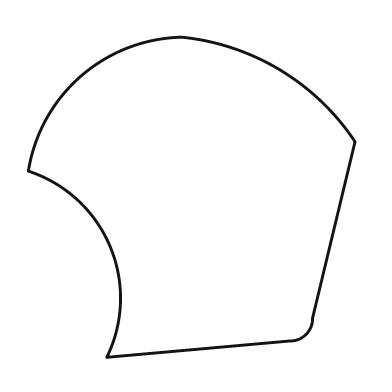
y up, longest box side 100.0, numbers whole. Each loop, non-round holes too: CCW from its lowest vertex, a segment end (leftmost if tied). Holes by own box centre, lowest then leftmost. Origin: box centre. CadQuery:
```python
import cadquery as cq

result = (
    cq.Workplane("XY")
    .moveTo(-26.0, -49.0)
    .lineTo(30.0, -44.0)
    .threePointArc((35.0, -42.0), (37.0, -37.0))
    .lineTo(50.0, 17.0)
    .threePointArc((27.0, 39.0), (-3.0, 49.0))
    .threePointArc((-34.0, 37.0), (-50.0, 8.0))
    .threePointArc((-25.0, -15.0), (-26.0, -49.0))
    .close()
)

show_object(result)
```